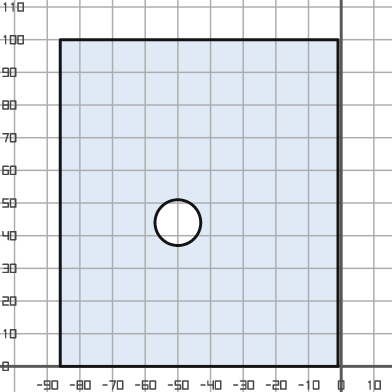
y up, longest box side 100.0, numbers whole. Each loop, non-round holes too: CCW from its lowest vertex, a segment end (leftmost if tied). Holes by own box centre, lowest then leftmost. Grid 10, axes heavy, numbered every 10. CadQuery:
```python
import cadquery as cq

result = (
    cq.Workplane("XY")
    .moveTo(-86.0, 0.0)
    .lineTo(-1.0, 0.0)
    .lineTo(-1.0, 100.0)
    .lineTo(-86.0, 100.0)
    .close()
    .moveTo(-50.0, 44.0)
    .circle(7.0)
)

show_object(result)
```